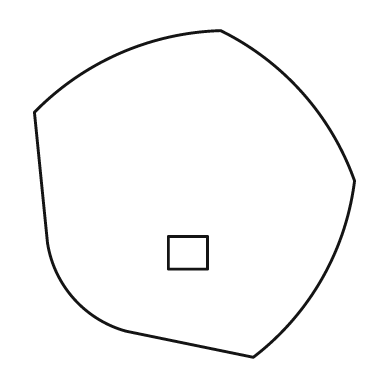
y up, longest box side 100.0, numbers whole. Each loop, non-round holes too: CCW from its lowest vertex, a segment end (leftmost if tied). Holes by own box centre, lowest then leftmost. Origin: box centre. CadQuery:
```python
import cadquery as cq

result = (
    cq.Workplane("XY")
    .moveTo(18.0, -50.0)
    .threePointArc((39.0, -26.0), (49.0, 4.0))
    .threePointArc((33.0, 31.0), (8.0, 50.0))
    .threePointArc((-23.0, 43.0), (-49.0, 25.0))
    .lineTo(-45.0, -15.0)
    .threePointArc((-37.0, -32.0), (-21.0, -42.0))
    .close()
    .moveTo(-8.0, -23.0)
    .lineTo(4.0, -23.0)
    .lineTo(4.0, -13.0)
    .lineTo(-8.0, -13.0)
    .close()
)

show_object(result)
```